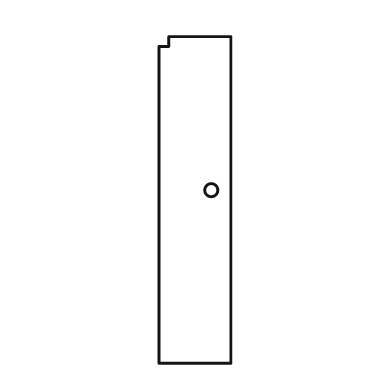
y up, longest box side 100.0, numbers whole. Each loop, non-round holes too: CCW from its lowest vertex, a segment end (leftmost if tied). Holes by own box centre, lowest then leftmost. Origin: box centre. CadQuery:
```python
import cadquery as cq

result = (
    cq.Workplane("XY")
    .moveTo(-11.0, -50.0)
    .lineTo(11.0, -50.0)
    .lineTo(11.0, 50.0)
    .lineTo(-8.0, 50.0)
    .lineTo(-8.0, 47.0)
    .lineTo(-11.0, 47.0)
    .close()
    .moveTo(5.0, 3.0)
    .circle(2.0)
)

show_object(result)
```